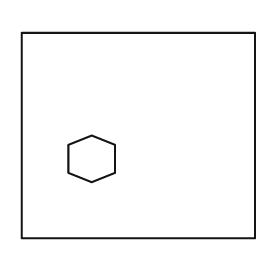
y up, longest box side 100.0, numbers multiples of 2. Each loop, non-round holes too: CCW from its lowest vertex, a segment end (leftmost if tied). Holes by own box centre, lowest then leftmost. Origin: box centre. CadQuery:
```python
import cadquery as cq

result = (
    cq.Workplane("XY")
    .moveTo(-50.0, -44.0)
    .lineTo(50.0, -44.0)
    .lineTo(50.0, 44.0)
    .lineTo(-50.0, 44.0)
    .close()
    .moveTo(-20.0, -20.0)
    .lineTo(-10.0, -16.0)
    .lineTo(-10.0, -4.0)
    .lineTo(-20.0, 0.0)
    .lineTo(-30.0, -4.0)
    .lineTo(-30.0, -16.0)
    .close()
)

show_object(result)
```